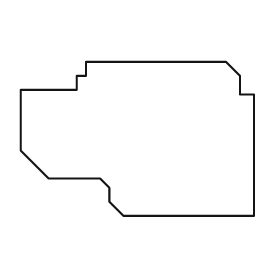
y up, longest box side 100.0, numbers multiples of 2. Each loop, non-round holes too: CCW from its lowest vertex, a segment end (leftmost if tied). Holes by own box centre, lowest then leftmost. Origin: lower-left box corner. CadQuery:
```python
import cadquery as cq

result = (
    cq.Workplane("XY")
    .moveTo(44.0, 0.0)
    .lineTo(100.0, 0.0)
    .lineTo(100.0, 52.0)
    .lineTo(94.0, 52.0)
    .lineTo(94.0, 60.0)
    .lineTo(88.0, 66.0)
    .lineTo(28.0, 66.0)
    .lineTo(28.0, 60.0)
    .lineTo(24.0, 60.0)
    .lineTo(24.0, 54.0)
    .lineTo(0.0, 54.0)
    .lineTo(0.0, 28.0)
    .lineTo(12.0, 16.0)
    .lineTo(34.0, 16.0)
    .lineTo(38.0, 12.0)
    .lineTo(38.0, 6.0)
    .close()
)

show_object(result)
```